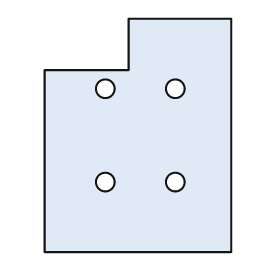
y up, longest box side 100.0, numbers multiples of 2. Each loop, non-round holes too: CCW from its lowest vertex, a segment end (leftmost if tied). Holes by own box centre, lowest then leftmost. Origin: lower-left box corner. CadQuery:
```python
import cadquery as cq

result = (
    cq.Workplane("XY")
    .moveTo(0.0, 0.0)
    .lineTo(80.0, 0.0)
    .lineTo(80.0, 100.0)
    .lineTo(36.0, 100.0)
    .lineTo(36.0, 78.0)
    .lineTo(0.0, 78.0)
    .close()
    .moveTo(26.0, 30.0)
    .circle(4.0)
    .moveTo(56.0, 30.0)
    .circle(4.0)
    .moveTo(26.0, 70.0)
    .circle(4.0)
    .moveTo(56.0, 70.0)
    .circle(4.0)
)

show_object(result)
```